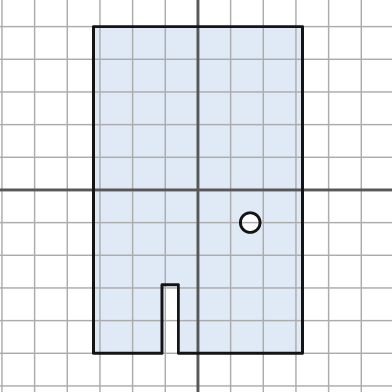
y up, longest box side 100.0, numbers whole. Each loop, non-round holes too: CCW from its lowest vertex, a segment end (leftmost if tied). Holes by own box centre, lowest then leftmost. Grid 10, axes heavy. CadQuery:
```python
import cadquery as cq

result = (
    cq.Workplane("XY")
    .moveTo(-32.0, -50.0)
    .lineTo(-11.0, -50.0)
    .lineTo(-11.0, -29.0)
    .lineTo(-6.0, -29.0)
    .lineTo(-6.0, -50.0)
    .lineTo(32.0, -50.0)
    .lineTo(32.0, 50.0)
    .lineTo(-32.0, 50.0)
    .close()
    .moveTo(16.0, -10.0)
    .circle(3.0)
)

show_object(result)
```